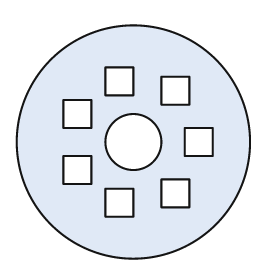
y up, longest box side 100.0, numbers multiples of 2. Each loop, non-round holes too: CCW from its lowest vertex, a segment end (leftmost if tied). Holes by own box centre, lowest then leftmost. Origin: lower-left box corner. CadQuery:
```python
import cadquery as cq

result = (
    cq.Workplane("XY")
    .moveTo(50.0, 50.0)
    .circle(50.0)
    .moveTo(38.0, 18.0)
    .lineTo(50.0, 18.0)
    .lineTo(50.0, 30.0)
    .lineTo(38.0, 30.0)
    .close()
    .moveTo(62.0, 22.0)
    .lineTo(74.0, 22.0)
    .lineTo(74.0, 34.0)
    .lineTo(62.0, 34.0)
    .close()
    .moveTo(20.0, 32.0)
    .lineTo(32.0, 32.0)
    .lineTo(32.0, 44.0)
    .lineTo(20.0, 44.0)
    .close()
    .moveTo(50.0, 50.0)
    .circle(12.0)
    .moveTo(72.0, 44.0)
    .lineTo(84.0, 44.0)
    .lineTo(84.0, 56.0)
    .lineTo(72.0, 56.0)
    .close()
    .moveTo(20.0, 56.0)
    .lineTo(32.0, 56.0)
    .lineTo(32.0, 68.0)
    .lineTo(20.0, 68.0)
    .close()
    .moveTo(62.0, 66.0)
    .lineTo(74.0, 66.0)
    .lineTo(74.0, 78.0)
    .lineTo(62.0, 78.0)
    .close()
    .moveTo(38.0, 70.0)
    .lineTo(50.0, 70.0)
    .lineTo(50.0, 82.0)
    .lineTo(38.0, 82.0)
    .close()
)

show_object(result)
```